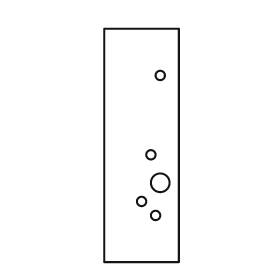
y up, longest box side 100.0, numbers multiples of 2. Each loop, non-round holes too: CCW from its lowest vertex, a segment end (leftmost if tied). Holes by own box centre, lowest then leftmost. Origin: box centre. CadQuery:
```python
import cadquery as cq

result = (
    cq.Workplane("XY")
    .moveTo(-16.0, -50.0)
    .lineTo(16.0, -50.0)
    .lineTo(16.0, 50.0)
    .lineTo(-16.0, 50.0)
    .close()
    .moveTo(6.0, -30.0)
    .circle(2.0)
    .moveTo(0.0, -24.0)
    .circle(2.0)
    .moveTo(8.0, -16.0)
    .circle(4.0)
    .moveTo(4.0, -4.0)
    .circle(2.0)
    .moveTo(8.0, 30.0)
    .circle(2.0)
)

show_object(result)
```